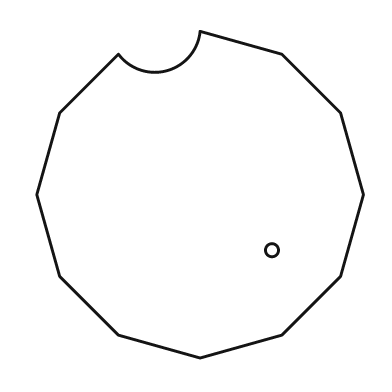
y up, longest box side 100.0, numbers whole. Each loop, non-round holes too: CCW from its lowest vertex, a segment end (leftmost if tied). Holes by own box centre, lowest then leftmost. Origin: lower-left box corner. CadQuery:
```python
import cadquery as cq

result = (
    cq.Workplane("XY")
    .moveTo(50.0, 0.0)
    .lineTo(75.0, 7.0)
    .lineTo(93.0, 25.0)
    .lineTo(100.0, 50.0)
    .lineTo(93.0, 75.0)
    .lineTo(75.0, 93.0)
    .lineTo(50.0, 100.0)
    .threePointArc((40.0, 88.0), (25.0, 93.0))
    .lineTo(7.0, 75.0)
    .lineTo(0.0, 50.0)
    .lineTo(7.0, 25.0)
    .lineTo(25.0, 7.0)
    .close()
    .moveTo(72.0, 33.0)
    .circle(2.0)
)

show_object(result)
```